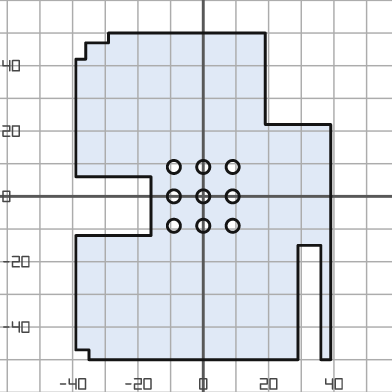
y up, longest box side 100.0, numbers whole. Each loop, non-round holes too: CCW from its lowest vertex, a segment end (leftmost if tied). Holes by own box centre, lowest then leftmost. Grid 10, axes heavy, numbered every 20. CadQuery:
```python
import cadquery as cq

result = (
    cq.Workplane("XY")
    .moveTo(-35.0, -50.0)
    .lineTo(29.0, -50.0)
    .lineTo(29.0, -15.0)
    .lineTo(36.0, -15.0)
    .lineTo(36.0, -50.0)
    .lineTo(39.0, -50.0)
    .lineTo(39.0, 22.0)
    .lineTo(19.0, 22.0)
    .lineTo(19.0, 50.0)
    .lineTo(-29.0, 50.0)
    .lineTo(-29.0, 47.0)
    .lineTo(-36.0, 47.0)
    .lineTo(-36.0, 42.0)
    .lineTo(-39.0, 42.0)
    .lineTo(-39.0, 6.0)
    .lineTo(-16.0, 6.0)
    .lineTo(-16.0, -12.0)
    .lineTo(-39.0, -12.0)
    .lineTo(-39.0, -47.0)
    .lineTo(-35.0, -47.0)
    .close()
    .moveTo(-9.0, -9.0)
    .circle(2.0)
    .moveTo(0.0, -9.0)
    .circle(2.0)
    .moveTo(9.0, -9.0)
    .circle(2.0)
    .moveTo(-9.0, 0.0)
    .circle(2.0)
    .moveTo(0.0, 0.0)
    .circle(2.0)
    .moveTo(9.0, 0.0)
    .circle(2.0)
    .moveTo(-9.0, 9.0)
    .circle(2.0)
    .moveTo(0.0, 9.0)
    .circle(2.0)
    .moveTo(9.0, 9.0)
    .circle(2.0)
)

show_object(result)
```